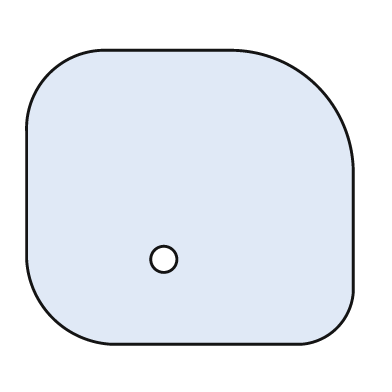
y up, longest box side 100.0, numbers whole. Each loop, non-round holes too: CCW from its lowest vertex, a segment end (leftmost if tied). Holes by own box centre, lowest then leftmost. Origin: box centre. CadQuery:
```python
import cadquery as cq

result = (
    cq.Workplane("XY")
    .moveTo(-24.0, -45.0)
    .lineTo(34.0, -45.0)
    .threePointArc((45.0, -40.0), (50.0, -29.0))
    .lineTo(50.0, 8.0)
    .threePointArc((39.0, 34.0), (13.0, 45.0))
    .lineTo(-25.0, 45.0)
    .threePointArc((-43.0, 38.0), (-50.0, 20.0))
    .lineTo(-50.0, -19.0)
    .threePointArc((-42.0, -37.0), (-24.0, -45.0))
    .close()
    .moveTo(-8.0, -19.0)
    .circle(4.0)
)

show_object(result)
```